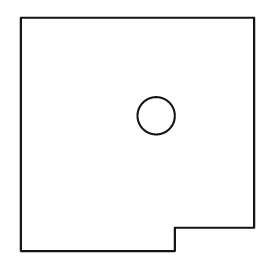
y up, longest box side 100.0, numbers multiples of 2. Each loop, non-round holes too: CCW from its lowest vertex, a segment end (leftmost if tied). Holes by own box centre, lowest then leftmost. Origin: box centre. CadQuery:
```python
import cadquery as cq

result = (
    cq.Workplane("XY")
    .moveTo(-50.0, -50.0)
    .lineTo(16.0, -50.0)
    .lineTo(16.0, -40.0)
    .lineTo(50.0, -40.0)
    .lineTo(50.0, 50.0)
    .lineTo(-50.0, 50.0)
    .close()
    .moveTo(8.0, 8.0)
    .circle(8.0)
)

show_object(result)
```